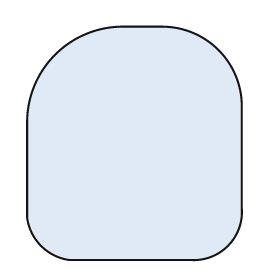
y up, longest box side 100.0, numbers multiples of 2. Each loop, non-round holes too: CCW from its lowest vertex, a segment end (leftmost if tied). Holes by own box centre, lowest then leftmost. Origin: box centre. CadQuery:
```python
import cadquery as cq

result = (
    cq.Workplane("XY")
    .moveTo(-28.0, -50.0)
    .lineTo(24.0, -50.0)
    .threePointArc((40.0, -44.0), (46.0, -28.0))
    .lineTo(46.0, 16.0)
    .threePointArc((36.0, 40.0), (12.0, 50.0))
    .lineTo(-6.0, 50.0)
    .threePointArc((-34.0, 38.0), (-46.0, 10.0))
    .lineTo(-46.0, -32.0)
    .threePointArc((-40.0, -44.0), (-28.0, -50.0))
    .close()
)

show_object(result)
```